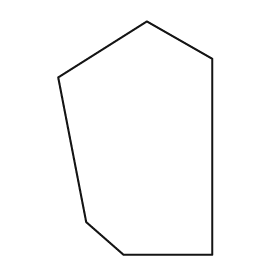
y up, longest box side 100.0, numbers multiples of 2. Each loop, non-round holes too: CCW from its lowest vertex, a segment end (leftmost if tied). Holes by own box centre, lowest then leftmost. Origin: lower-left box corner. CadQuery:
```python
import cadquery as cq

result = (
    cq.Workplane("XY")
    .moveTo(28.0, 0.0)
    .lineTo(66.0, 0.0)
    .lineTo(66.0, 84.0)
    .lineTo(38.0, 100.0)
    .lineTo(0.0, 76.0)
    .lineTo(12.0, 14.0)
    .close()
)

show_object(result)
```